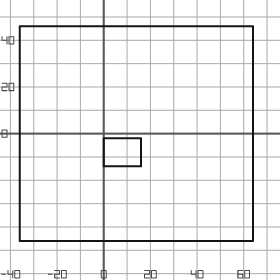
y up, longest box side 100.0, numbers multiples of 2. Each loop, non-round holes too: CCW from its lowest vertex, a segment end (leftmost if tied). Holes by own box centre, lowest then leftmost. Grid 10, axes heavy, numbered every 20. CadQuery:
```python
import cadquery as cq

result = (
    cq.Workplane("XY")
    .moveTo(-36.0, -46.0)
    .lineTo(64.0, -46.0)
    .lineTo(64.0, 46.0)
    .lineTo(-36.0, 46.0)
    .close()
    .moveTo(0.0, -14.0)
    .lineTo(16.0, -14.0)
    .lineTo(16.0, -2.0)
    .lineTo(0.0, -2.0)
    .close()
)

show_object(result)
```